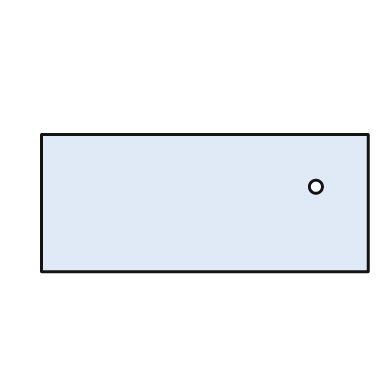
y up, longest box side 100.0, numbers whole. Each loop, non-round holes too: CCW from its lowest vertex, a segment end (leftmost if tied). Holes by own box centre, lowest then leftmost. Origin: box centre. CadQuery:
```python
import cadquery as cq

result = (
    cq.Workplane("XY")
    .moveTo(-50.0, -21.0)
    .lineTo(50.0, -21.0)
    .lineTo(50.0, 21.0)
    .lineTo(-50.0, 21.0)
    .close()
    .moveTo(34.0, 5.0)
    .circle(2.0)
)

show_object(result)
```